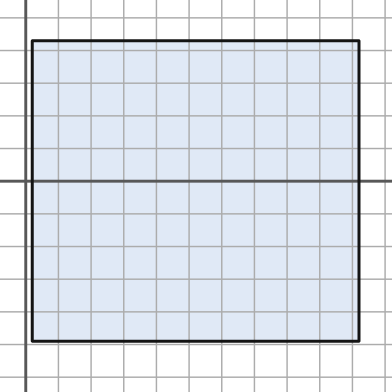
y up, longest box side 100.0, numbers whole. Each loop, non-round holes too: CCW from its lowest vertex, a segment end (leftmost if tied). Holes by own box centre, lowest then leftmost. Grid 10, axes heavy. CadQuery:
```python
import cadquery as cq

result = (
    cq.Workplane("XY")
    .moveTo(2.0, -49.0)
    .lineTo(102.0, -49.0)
    .lineTo(102.0, 43.0)
    .lineTo(2.0, 43.0)
    .close()
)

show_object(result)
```